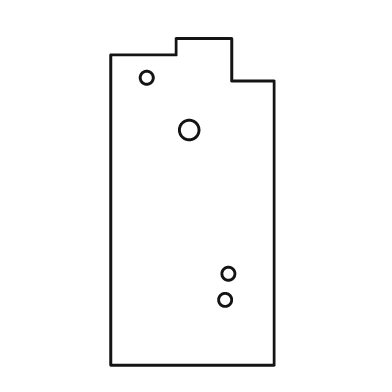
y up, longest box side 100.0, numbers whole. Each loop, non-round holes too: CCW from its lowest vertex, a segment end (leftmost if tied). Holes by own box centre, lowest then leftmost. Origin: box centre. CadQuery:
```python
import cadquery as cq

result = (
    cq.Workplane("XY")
    .moveTo(-25.0, -50.0)
    .lineTo(25.0, -50.0)
    .lineTo(25.0, 37.0)
    .lineTo(12.0, 37.0)
    .lineTo(12.0, 50.0)
    .lineTo(-5.0, 50.0)
    .lineTo(-5.0, 45.0)
    .lineTo(-25.0, 45.0)
    .close()
    .moveTo(10.0, -30.0)
    .circle(2.0)
    .moveTo(11.0, -22.0)
    .circle(2.0)
    .moveTo(-1.0, 22.0)
    .circle(3.0)
    .moveTo(-14.0, 38.0)
    .circle(2.0)
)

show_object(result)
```